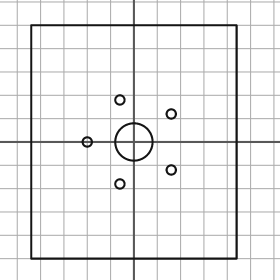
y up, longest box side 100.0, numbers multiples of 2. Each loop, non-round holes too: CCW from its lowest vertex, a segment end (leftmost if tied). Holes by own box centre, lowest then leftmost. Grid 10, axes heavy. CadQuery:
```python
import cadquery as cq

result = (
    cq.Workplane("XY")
    .moveTo(-44.0, -50.0)
    .lineTo(44.0, -50.0)
    .lineTo(44.0, 50.0)
    .lineTo(-44.0, 50.0)
    .close()
    .moveTo(-6.0, -18.0)
    .circle(2.0)
    .moveTo(16.0, -12.0)
    .circle(2.0)
    .moveTo(-20.0, 0.0)
    .circle(2.0)
    .moveTo(0.0, 0.0)
    .circle(8.0)
    .moveTo(16.0, 12.0)
    .circle(2.0)
    .moveTo(-6.0, 18.0)
    .circle(2.0)
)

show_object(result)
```